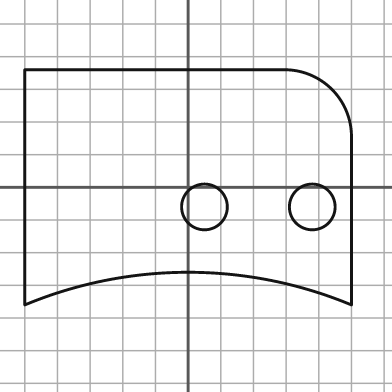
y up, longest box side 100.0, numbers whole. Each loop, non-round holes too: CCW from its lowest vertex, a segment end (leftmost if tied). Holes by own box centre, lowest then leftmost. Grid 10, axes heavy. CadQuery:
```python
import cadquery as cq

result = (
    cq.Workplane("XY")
    .moveTo(-50.0, -36.0)
    .threePointArc((0.0, -26.0), (50.0, -36.0))
    .lineTo(50.0, 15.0)
    .threePointArc((44.0, 30.0), (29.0, 36.0))
    .lineTo(-50.0, 36.0)
    .close()
    .moveTo(5.0, -6.0)
    .circle(7.0)
    .moveTo(38.0, -6.0)
    .circle(7.0)
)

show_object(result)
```